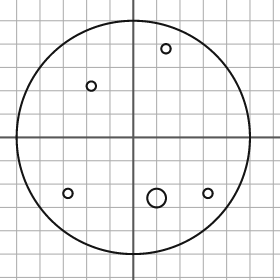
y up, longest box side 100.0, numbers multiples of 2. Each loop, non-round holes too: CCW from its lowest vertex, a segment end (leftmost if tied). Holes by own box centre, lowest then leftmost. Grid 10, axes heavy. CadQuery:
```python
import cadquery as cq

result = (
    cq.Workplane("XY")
    .moveTo(0.0, 0.0)
    .circle(50.0)
    .moveTo(10.0, -26.0)
    .circle(4.0)
    .moveTo(-28.0, -24.0)
    .circle(2.0)
    .moveTo(32.0, -24.0)
    .circle(2.0)
    .moveTo(-18.0, 22.0)
    .circle(2.0)
    .moveTo(14.0, 38.0)
    .circle(2.0)
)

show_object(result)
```